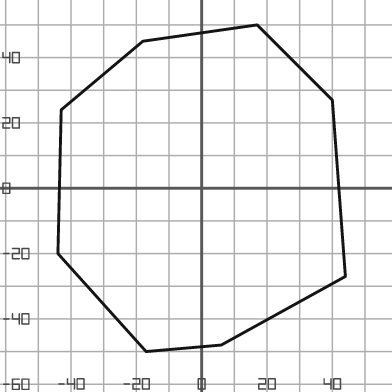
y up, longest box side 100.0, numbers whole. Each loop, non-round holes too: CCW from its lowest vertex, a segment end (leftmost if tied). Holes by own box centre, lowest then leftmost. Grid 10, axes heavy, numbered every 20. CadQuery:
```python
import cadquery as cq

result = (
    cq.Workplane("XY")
    .moveTo(-17.0, -50.0)
    .lineTo(6.0, -48.0)
    .lineTo(44.0, -27.0)
    .lineTo(40.0, 27.0)
    .lineTo(17.0, 50.0)
    .lineTo(-18.0, 45.0)
    .lineTo(-43.0, 24.0)
    .lineTo(-44.0, -20.0)
    .close()
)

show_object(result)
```